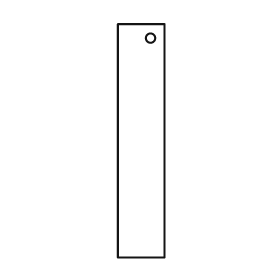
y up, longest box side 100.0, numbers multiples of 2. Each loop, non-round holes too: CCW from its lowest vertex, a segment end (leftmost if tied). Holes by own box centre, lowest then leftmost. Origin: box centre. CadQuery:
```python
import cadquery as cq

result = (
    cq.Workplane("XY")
    .moveTo(-10.0, -50.0)
    .lineTo(10.0, -50.0)
    .lineTo(10.0, 50.0)
    .lineTo(-10.0, 50.0)
    .close()
    .moveTo(4.0, 44.0)
    .circle(2.0)
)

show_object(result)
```